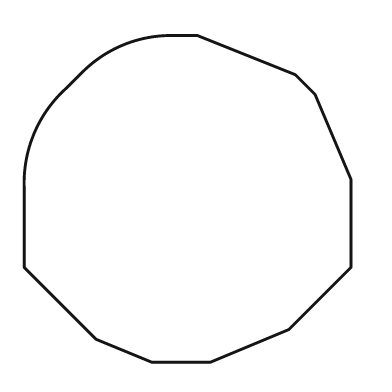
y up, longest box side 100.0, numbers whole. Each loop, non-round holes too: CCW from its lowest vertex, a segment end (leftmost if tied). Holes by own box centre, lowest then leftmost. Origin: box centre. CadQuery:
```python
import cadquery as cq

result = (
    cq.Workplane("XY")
    .moveTo(-11.0, -50.0)
    .lineTo(7.0, -50.0)
    .lineTo(31.0, -40.0)
    .lineTo(50.0, -21.0)
    .lineTo(50.0, 6.0)
    .lineTo(39.0, 32.0)
    .lineTo(33.0, 38.0)
    .lineTo(3.0, 50.0)
    .lineTo(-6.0, 50.0)
    .threePointArc((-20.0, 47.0), (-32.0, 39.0))
    .lineTo(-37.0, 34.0)
    .threePointArc((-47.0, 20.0), (-50.0, 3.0))
    .lineTo(-50.0, -21.0)
    .lineTo(-28.0, -43.0)
    .close()
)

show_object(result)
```